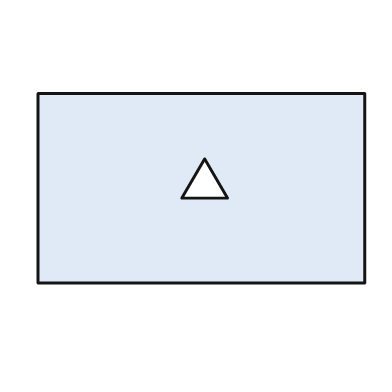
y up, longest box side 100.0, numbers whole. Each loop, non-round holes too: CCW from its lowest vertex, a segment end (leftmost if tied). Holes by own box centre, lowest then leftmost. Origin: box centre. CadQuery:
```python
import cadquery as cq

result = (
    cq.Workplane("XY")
    .moveTo(-50.0, -29.0)
    .lineTo(50.0, -29.0)
    .lineTo(50.0, 29.0)
    .lineTo(-50.0, 29.0)
    .close()
    .moveTo(-6.0, -3.0)
    .lineTo(8.0, -3.0)
    .lineTo(1.0, 9.0)
    .close()
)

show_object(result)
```